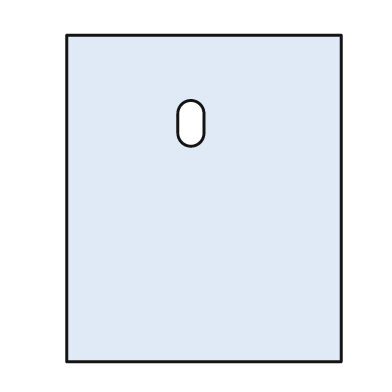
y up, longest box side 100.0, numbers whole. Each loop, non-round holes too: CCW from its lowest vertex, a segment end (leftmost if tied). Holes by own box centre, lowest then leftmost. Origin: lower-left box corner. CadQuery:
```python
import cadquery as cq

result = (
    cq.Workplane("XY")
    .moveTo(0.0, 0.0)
    .lineTo(84.0, 0.0)
    .lineTo(84.0, 100.0)
    .lineTo(0.0, 100.0)
    .close()
    .moveTo(34.0, 70.0)
    .threePointArc((38.0, 66.0), (42.0, 70.0))
    .lineTo(42.0, 76.0)
    .threePointArc((38.0, 80.0), (34.0, 76.0))
    .close()
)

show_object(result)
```